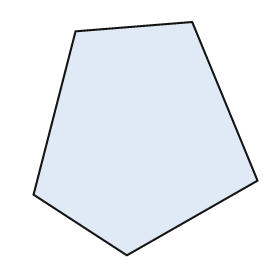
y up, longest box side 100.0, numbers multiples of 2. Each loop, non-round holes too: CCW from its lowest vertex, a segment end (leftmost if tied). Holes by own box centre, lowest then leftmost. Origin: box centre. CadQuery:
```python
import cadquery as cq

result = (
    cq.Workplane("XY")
    .moveTo(-8.0, -50.0)
    .lineTo(48.0, -18.0)
    .lineTo(20.0, 50.0)
    .lineTo(-30.0, 46.0)
    .lineTo(-48.0, -24.0)
    .close()
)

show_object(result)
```